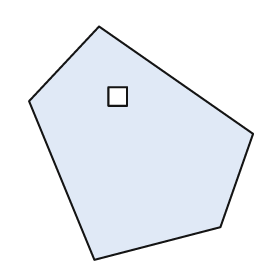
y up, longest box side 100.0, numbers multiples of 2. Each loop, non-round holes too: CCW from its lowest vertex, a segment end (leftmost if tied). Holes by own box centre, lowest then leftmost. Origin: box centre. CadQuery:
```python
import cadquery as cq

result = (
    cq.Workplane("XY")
    .moveTo(-20.0, -50.0)
    .lineTo(34.0, -36.0)
    .lineTo(48.0, 4.0)
    .lineTo(-18.0, 50.0)
    .lineTo(-48.0, 18.0)
    .close()
    .moveTo(-14.0, 16.0)
    .lineTo(-6.0, 16.0)
    .lineTo(-6.0, 24.0)
    .lineTo(-14.0, 24.0)
    .close()
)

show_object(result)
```